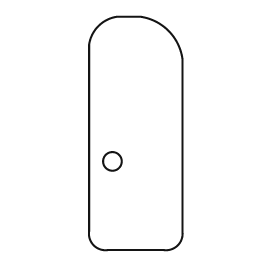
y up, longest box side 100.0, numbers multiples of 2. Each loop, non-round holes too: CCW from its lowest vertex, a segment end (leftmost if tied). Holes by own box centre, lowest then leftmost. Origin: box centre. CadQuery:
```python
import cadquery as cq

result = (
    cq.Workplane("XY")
    .moveTo(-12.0, -50.0)
    .lineTo(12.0, -50.0)
    .threePointArc((18.0, -48.0), (20.0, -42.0))
    .lineTo(20.0, 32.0)
    .threePointArc((14.0, 44.0), (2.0, 50.0))
    .lineTo(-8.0, 50.0)
    .threePointArc((-16.0, 46.0), (-20.0, 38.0))
    .lineTo(-20.0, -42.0)
    .threePointArc((-18.0, -48.0), (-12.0, -50.0))
    .close()
    .moveTo(-10.0, -12.0)
    .circle(4.0)
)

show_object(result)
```